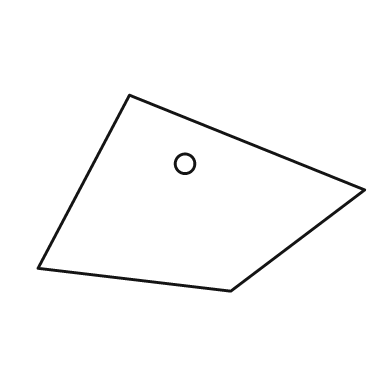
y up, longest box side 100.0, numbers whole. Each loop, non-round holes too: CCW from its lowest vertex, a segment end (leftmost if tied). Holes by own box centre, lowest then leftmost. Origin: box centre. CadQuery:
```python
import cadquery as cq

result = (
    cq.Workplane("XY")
    .moveTo(9.0, -30.0)
    .lineTo(50.0, 1.0)
    .lineTo(-22.0, 30.0)
    .lineTo(-50.0, -23.0)
    .close()
    .moveTo(-5.0, 9.0)
    .circle(3.0)
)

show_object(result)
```